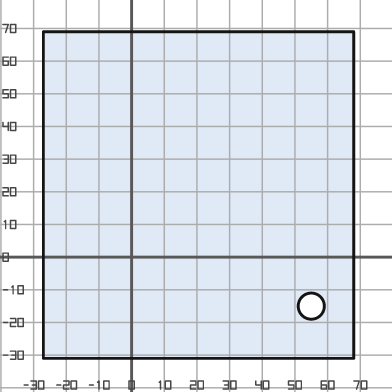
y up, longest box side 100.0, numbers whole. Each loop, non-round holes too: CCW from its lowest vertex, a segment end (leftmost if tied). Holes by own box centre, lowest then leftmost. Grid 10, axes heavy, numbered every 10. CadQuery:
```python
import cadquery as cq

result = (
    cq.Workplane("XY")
    .moveTo(-27.0, -31.0)
    .lineTo(68.0, -31.0)
    .lineTo(68.0, 69.0)
    .lineTo(-27.0, 69.0)
    .close()
    .moveTo(55.0, -15.0)
    .circle(4.0)
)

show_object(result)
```